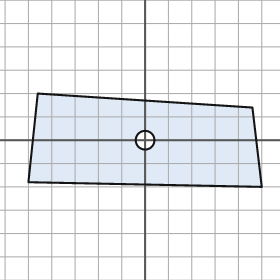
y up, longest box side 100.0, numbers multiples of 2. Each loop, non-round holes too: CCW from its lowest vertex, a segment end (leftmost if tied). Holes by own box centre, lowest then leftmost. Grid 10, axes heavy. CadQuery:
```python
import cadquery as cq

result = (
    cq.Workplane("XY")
    .moveTo(50.0, -20.0)
    .lineTo(46.0, 14.0)
    .lineTo(-46.0, 20.0)
    .lineTo(-50.0, -18.0)
    .close()
    .moveTo(0.0, 0.0)
    .circle(4.0)
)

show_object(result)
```